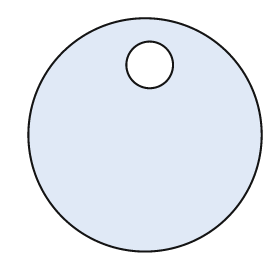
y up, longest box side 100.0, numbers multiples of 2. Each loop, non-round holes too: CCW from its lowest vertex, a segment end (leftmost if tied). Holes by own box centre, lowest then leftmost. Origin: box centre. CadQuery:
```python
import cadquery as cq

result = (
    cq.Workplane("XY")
    .moveTo(0.0, 0.0)
    .circle(50.0)
    .moveTo(2.0, 30.0)
    .circle(10.0)
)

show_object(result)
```